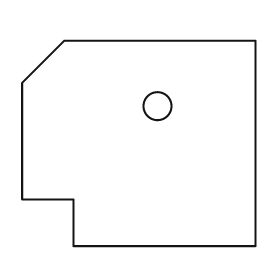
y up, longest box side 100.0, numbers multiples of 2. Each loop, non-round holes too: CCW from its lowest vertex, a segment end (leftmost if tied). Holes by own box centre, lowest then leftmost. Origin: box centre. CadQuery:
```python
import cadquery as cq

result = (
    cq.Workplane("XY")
    .moveTo(-28.0, -44.0)
    .lineTo(50.0, -44.0)
    .lineTo(50.0, 44.0)
    .lineTo(-32.0, 44.0)
    .lineTo(-50.0, 26.0)
    .lineTo(-50.0, -24.0)
    .lineTo(-28.0, -24.0)
    .close()
    .moveTo(8.0, 16.0)
    .circle(6.0)
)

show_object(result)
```